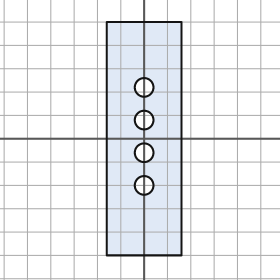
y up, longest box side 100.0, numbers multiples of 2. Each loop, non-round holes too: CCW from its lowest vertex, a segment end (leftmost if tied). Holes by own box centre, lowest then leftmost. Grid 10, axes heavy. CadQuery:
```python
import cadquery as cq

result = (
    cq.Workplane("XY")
    .moveTo(-16.0, -50.0)
    .lineTo(16.0, -50.0)
    .lineTo(16.0, 50.0)
    .lineTo(-16.0, 50.0)
    .close()
    .moveTo(0.0, -20.0)
    .circle(4.0)
    .moveTo(0.0, -6.0)
    .circle(4.0)
    .moveTo(0.0, 8.0)
    .circle(4.0)
    .moveTo(0.0, 22.0)
    .circle(4.0)
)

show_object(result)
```